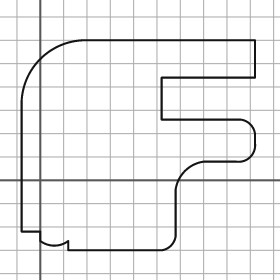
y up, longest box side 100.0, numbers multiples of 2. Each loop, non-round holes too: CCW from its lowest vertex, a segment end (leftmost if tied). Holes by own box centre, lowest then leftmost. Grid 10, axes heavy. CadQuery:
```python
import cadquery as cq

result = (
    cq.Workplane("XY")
    .moveTo(12.0, -30.0)
    .lineTo(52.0, -30.0)
    .threePointArc((56.0, -28.0), (58.0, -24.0))
    .lineTo(58.0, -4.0)
    .threePointArc((62.0, 4.0), (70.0, 8.0))
    .lineTo(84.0, 8.0)
    .threePointArc((90.0, 10.0), (92.0, 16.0))
    .lineTo(92.0, 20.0)
    .threePointArc((90.0, 24.0), (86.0, 26.0))
    .lineTo(52.0, 26.0)
    .lineTo(52.0, 44.0)
    .lineTo(92.0, 44.0)
    .lineTo(92.0, 60.0)
    .lineTo(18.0, 60.0)
    .threePointArc((0.0, 52.0), (-8.0, 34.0))
    .lineTo(-8.0, -22.0)
    .lineTo(0.0, -22.0)
    .lineTo(0.0, -26.0)
    .threePointArc((6.0, -28.0), (12.0, -26.0))
    .close()
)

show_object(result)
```